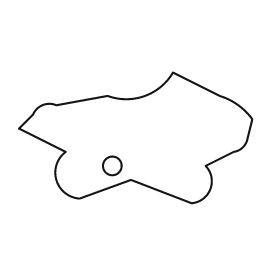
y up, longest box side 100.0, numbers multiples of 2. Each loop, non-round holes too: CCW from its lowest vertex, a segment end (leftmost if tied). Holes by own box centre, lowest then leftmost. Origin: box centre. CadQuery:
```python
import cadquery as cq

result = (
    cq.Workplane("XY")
    .moveTo(24.0, -28.0)
    .threePointArc((32.0, -22.0), (30.0, -12.0))
    .lineTo(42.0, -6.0)
    .threePointArc((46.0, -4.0), (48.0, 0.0))
    .lineTo(50.0, 8.0)
    .threePointArc((44.0, 14.0), (36.0, 18.0))
    .lineTo(16.0, 28.0)
    .threePointArc((4.0, 18.0), (-12.0, 18.0))
    .lineTo(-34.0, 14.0)
    .threePointArc((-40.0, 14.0), (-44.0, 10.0))
    .lineTo(-50.0, 4.0)
    .lineTo(-30.0, -6.0)
    .threePointArc((-34.0, -18.0), (-24.0, -26.0))
    .lineTo(-2.0, -18.0)
    .close()
    .moveTo(-10.0, -12.0)
    .circle(4.0)
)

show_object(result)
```